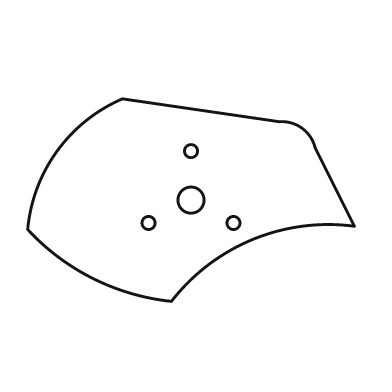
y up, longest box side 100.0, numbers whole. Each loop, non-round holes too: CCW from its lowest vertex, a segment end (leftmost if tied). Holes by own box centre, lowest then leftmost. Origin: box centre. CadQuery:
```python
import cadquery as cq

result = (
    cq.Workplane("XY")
    .moveTo(-6.0, -31.0)
    .threePointArc((19.0, -12.0), (50.0, -8.0))
    .lineTo(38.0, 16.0)
    .threePointArc((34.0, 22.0), (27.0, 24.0))
    .lineTo(-21.0, 31.0)
    .threePointArc((-41.0, 15.0), (-50.0, -9.0))
    .threePointArc((-30.0, -24.0), (-6.0, -31.0))
    .close()
    .moveTo(-13.0, -7.0)
    .circle(2.0)
    .moveTo(13.0, -7.0)
    .circle(2.0)
    .moveTo(0.0, 0.0)
    .circle(4.0)
    .moveTo(0.0, 15.0)
    .circle(2.0)
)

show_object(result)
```